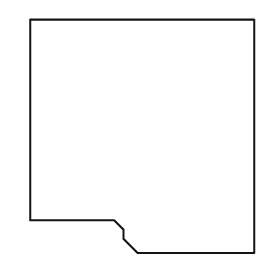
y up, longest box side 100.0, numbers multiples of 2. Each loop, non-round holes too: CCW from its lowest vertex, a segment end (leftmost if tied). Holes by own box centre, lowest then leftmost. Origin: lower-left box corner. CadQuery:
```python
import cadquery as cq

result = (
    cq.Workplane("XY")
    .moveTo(46.0, 0.0)
    .lineTo(96.0, 0.0)
    .lineTo(96.0, 100.0)
    .lineTo(0.0, 100.0)
    .lineTo(0.0, 14.0)
    .lineTo(36.0, 14.0)
    .lineTo(40.0, 10.0)
    .lineTo(40.0, 6.0)
    .close()
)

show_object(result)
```